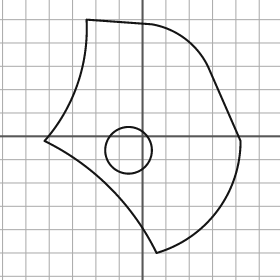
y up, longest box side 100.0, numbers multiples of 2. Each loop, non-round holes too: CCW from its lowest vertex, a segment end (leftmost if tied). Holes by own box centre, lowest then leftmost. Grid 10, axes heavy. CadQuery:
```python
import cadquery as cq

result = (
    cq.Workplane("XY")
    .moveTo(6.0, -50.0)
    .threePointArc((32.0, -32.0), (42.0, -2.0))
    .lineTo(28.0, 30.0)
    .threePointArc((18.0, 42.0), (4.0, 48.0))
    .lineTo(-24.0, 50.0)
    .threePointArc((-28.0, 22.0), (-42.0, -2.0))
    .threePointArc((-14.0, -22.0), (6.0, -50.0))
    .close()
    .moveTo(-6.0, -6.0)
    .circle(10.0)
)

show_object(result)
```